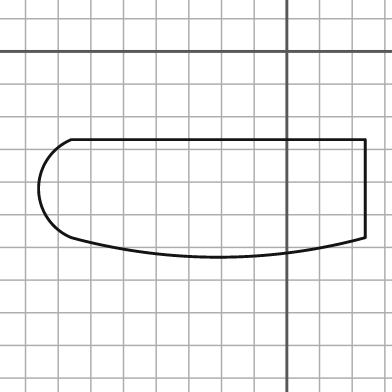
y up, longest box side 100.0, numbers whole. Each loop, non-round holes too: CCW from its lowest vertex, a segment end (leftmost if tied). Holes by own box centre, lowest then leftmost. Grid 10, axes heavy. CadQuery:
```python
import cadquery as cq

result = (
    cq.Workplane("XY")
    .moveTo(-66.0, -57.0)
    .threePointArc((-21.0, -63.0), (24.0, -57.0))
    .lineTo(24.0, -27.0)
    .lineTo(-66.0, -27.0)
    .threePointArc((-76.0, -42.0), (-66.0, -57.0))
    .close()
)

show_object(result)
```